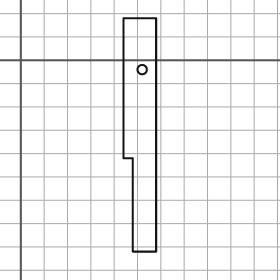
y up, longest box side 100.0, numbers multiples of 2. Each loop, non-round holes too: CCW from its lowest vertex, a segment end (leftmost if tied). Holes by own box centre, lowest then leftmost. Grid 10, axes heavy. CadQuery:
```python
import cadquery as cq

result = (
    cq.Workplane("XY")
    .moveTo(48.0, -82.0)
    .lineTo(58.0, -82.0)
    .lineTo(58.0, 18.0)
    .lineTo(44.0, 18.0)
    .lineTo(44.0, -42.0)
    .lineTo(48.0, -42.0)
    .close()
    .moveTo(52.0, -4.0)
    .circle(2.0)
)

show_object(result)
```